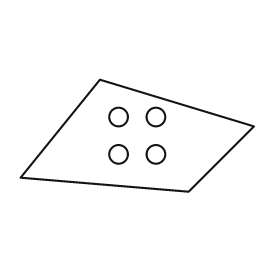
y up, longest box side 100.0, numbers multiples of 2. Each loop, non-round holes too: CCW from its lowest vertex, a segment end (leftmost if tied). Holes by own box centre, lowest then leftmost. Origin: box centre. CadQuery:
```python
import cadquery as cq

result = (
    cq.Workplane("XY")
    .moveTo(22.0, -24.0)
    .lineTo(50.0, 4.0)
    .lineTo(-16.0, 24.0)
    .lineTo(-50.0, -18.0)
    .close()
    .moveTo(-8.0, -8.0)
    .circle(4.0)
    .moveTo(8.0, -8.0)
    .circle(4.0)
    .moveTo(-8.0, 8.0)
    .circle(4.0)
    .moveTo(8.0, 8.0)
    .circle(4.0)
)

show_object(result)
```